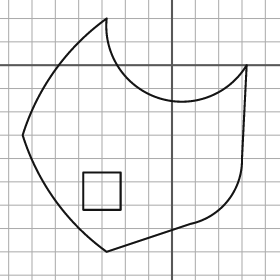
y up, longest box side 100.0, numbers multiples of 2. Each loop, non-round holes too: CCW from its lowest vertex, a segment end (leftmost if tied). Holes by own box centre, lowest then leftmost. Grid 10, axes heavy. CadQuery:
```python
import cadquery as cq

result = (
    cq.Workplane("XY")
    .moveTo(-28.0, -80.0)
    .lineTo(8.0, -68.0)
    .threePointArc((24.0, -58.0), (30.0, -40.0))
    .lineTo(32.0, 0.0)
    .threePointArc((-6.0, -14.0), (-28.0, 20.0))
    .threePointArc((-50.0, -2.0), (-64.0, -30.0))
    .threePointArc((-50.0, -58.0), (-28.0, -80.0))
    .close()
    .moveTo(-38.0, -62.0)
    .lineTo(-22.0, -62.0)
    .lineTo(-22.0, -46.0)
    .lineTo(-38.0, -46.0)
    .close()
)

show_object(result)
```